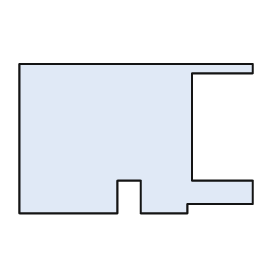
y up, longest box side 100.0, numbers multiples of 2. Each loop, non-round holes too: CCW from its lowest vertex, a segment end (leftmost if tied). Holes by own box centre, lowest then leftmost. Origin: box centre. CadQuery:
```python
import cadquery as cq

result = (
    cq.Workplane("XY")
    .moveTo(-50.0, -32.0)
    .lineTo(-8.0, -32.0)
    .lineTo(-8.0, -18.0)
    .lineTo(2.0, -18.0)
    .lineTo(2.0, -32.0)
    .lineTo(22.0, -32.0)
    .lineTo(22.0, -28.0)
    .lineTo(50.0, -28.0)
    .lineTo(50.0, -18.0)
    .lineTo(24.0, -18.0)
    .lineTo(24.0, 28.0)
    .lineTo(50.0, 28.0)
    .lineTo(50.0, 32.0)
    .lineTo(-50.0, 32.0)
    .close()
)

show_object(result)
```